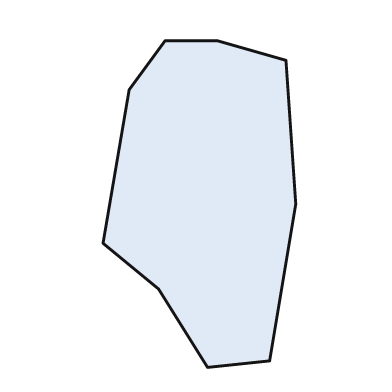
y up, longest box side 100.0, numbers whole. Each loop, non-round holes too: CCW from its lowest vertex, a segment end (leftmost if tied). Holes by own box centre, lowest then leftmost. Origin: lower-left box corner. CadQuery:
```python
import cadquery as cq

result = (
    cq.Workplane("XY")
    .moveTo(32.0, 0.0)
    .lineTo(51.0, 2.0)
    .lineTo(59.0, 50.0)
    .lineTo(56.0, 94.0)
    .lineTo(35.0, 100.0)
    .lineTo(19.0, 100.0)
    .lineTo(8.0, 85.0)
    .lineTo(0.0, 38.0)
    .lineTo(17.0, 24.0)
    .close()
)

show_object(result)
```